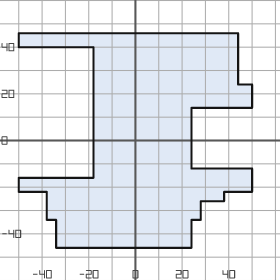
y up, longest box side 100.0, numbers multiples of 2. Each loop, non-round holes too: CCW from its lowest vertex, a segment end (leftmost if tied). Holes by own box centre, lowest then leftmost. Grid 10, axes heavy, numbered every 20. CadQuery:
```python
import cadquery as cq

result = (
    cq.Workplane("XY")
    .moveTo(-34.0, -46.0)
    .lineTo(24.0, -46.0)
    .lineTo(24.0, -34.0)
    .lineTo(28.0, -34.0)
    .lineTo(28.0, -26.0)
    .lineTo(38.0, -26.0)
    .lineTo(38.0, -22.0)
    .lineTo(50.0, -22.0)
    .lineTo(50.0, -12.0)
    .lineTo(24.0, -12.0)
    .lineTo(24.0, 14.0)
    .lineTo(50.0, 14.0)
    .lineTo(50.0, 24.0)
    .lineTo(44.0, 24.0)
    .lineTo(44.0, 46.0)
    .lineTo(-50.0, 46.0)
    .lineTo(-50.0, 40.0)
    .lineTo(-18.0, 40.0)
    .lineTo(-18.0, -16.0)
    .lineTo(-50.0, -16.0)
    .lineTo(-50.0, -22.0)
    .lineTo(-38.0, -22.0)
    .lineTo(-38.0, -34.0)
    .lineTo(-34.0, -34.0)
    .close()
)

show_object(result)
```